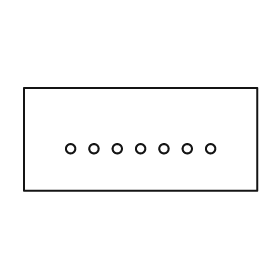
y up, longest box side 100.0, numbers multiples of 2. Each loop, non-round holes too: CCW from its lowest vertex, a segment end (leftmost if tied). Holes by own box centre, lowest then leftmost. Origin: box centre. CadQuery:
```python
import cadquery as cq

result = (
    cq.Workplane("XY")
    .moveTo(-50.0, -22.0)
    .lineTo(50.0, -22.0)
    .lineTo(50.0, 22.0)
    .lineTo(-50.0, 22.0)
    .close()
    .moveTo(-30.0, -4.0)
    .circle(2.0)
    .moveTo(-20.0, -4.0)
    .circle(2.0)
    .moveTo(-10.0, -4.0)
    .circle(2.0)
    .moveTo(0.0, -4.0)
    .circle(2.0)
    .moveTo(10.0, -4.0)
    .circle(2.0)
    .moveTo(20.0, -4.0)
    .circle(2.0)
    .moveTo(30.0, -4.0)
    .circle(2.0)
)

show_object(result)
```